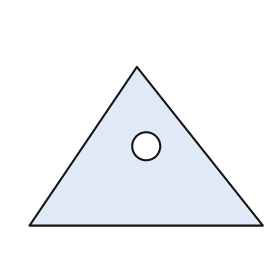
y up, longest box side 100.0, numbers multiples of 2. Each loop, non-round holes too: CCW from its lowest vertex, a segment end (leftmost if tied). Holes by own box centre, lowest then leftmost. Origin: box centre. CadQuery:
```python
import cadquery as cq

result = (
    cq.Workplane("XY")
    .moveTo(-50.0, -34.0)
    .lineTo(50.0, -34.0)
    .lineTo(-4.0, 34.0)
    .close()
    .moveTo(0.0, 0.0)
    .circle(6.0)
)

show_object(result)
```